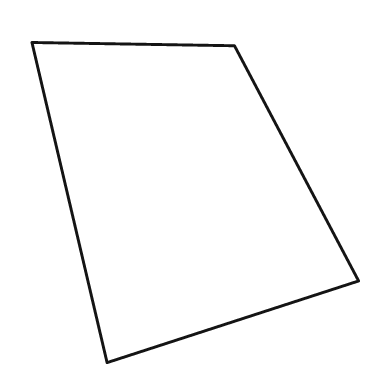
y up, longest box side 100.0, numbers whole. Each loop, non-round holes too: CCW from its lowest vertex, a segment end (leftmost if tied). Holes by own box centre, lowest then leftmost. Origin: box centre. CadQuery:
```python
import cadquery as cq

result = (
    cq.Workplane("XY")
    .moveTo(-27.0, -49.0)
    .lineTo(50.0, -24.0)
    .lineTo(12.0, 48.0)
    .lineTo(-50.0, 49.0)
    .close()
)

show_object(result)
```